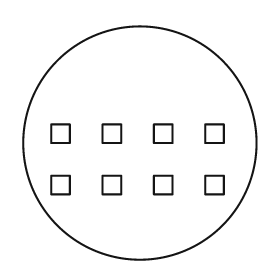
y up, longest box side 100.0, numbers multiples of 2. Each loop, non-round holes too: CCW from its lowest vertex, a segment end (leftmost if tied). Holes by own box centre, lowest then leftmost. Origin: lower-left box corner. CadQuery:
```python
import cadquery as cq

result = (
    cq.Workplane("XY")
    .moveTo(50.0, 50.0)
    .circle(50.0)
    .moveTo(12.0, 28.0)
    .lineTo(20.0, 28.0)
    .lineTo(20.0, 36.0)
    .lineTo(12.0, 36.0)
    .close()
    .moveTo(34.0, 28.0)
    .lineTo(42.0, 28.0)
    .lineTo(42.0, 36.0)
    .lineTo(34.0, 36.0)
    .close()
    .moveTo(56.0, 28.0)
    .lineTo(64.0, 28.0)
    .lineTo(64.0, 36.0)
    .lineTo(56.0, 36.0)
    .close()
    .moveTo(78.0, 28.0)
    .lineTo(86.0, 28.0)
    .lineTo(86.0, 36.0)
    .lineTo(78.0, 36.0)
    .close()
    .moveTo(12.0, 50.0)
    .lineTo(20.0, 50.0)
    .lineTo(20.0, 58.0)
    .lineTo(12.0, 58.0)
    .close()
    .moveTo(34.0, 50.0)
    .lineTo(42.0, 50.0)
    .lineTo(42.0, 58.0)
    .lineTo(34.0, 58.0)
    .close()
    .moveTo(56.0, 50.0)
    .lineTo(64.0, 50.0)
    .lineTo(64.0, 58.0)
    .lineTo(56.0, 58.0)
    .close()
    .moveTo(78.0, 50.0)
    .lineTo(86.0, 50.0)
    .lineTo(86.0, 58.0)
    .lineTo(78.0, 58.0)
    .close()
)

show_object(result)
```